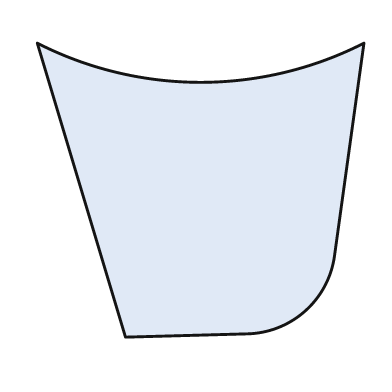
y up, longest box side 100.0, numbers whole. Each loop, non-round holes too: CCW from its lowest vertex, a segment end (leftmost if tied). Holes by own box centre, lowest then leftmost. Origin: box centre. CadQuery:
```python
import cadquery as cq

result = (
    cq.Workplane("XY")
    .moveTo(-23.0, -45.0)
    .lineTo(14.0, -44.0)
    .threePointArc((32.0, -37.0), (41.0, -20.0))
    .lineTo(50.0, 45.0)
    .threePointArc((0.0, 33.0), (-50.0, 45.0))
    .close()
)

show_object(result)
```